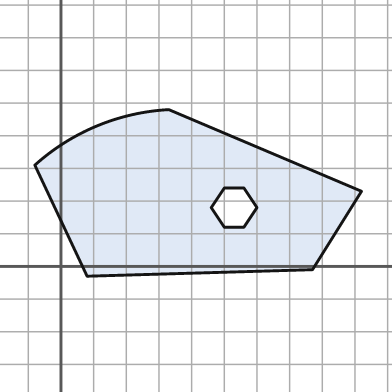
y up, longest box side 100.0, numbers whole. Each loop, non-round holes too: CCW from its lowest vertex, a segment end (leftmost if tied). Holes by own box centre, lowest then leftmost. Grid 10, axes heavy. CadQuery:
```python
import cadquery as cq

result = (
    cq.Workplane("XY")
    .moveTo(8.0, -3.0)
    .lineTo(77.0, -1.0)
    .lineTo(92.0, 23.0)
    .lineTo(33.0, 48.0)
    .threePointArc((11.0, 43.0), (-8.0, 31.0))
    .close()
    .moveTo(50.0, 12.0)
    .lineTo(56.0, 12.0)
    .lineTo(60.0, 18.0)
    .lineTo(56.0, 24.0)
    .lineTo(50.0, 24.0)
    .lineTo(46.0, 18.0)
    .close()
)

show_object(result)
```